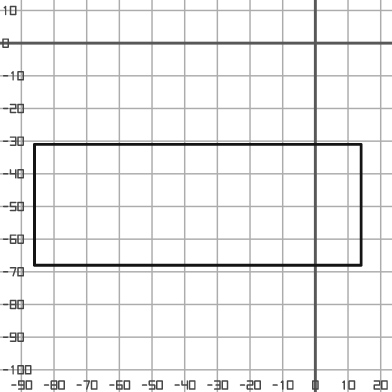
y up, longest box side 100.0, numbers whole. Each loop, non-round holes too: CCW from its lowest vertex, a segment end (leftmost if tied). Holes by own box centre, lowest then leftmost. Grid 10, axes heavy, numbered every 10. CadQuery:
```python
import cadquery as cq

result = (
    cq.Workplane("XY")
    .moveTo(-86.0, -68.0)
    .lineTo(14.0, -68.0)
    .lineTo(14.0, -31.0)
    .lineTo(-86.0, -31.0)
    .close()
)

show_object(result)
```